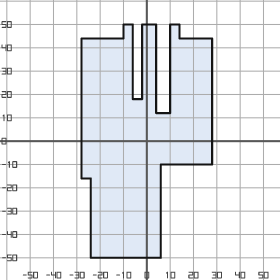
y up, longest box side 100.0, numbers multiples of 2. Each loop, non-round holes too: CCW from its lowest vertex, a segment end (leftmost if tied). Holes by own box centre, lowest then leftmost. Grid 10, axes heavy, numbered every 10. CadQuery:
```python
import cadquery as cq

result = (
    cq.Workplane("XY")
    .moveTo(-24.0, -50.0)
    .lineTo(6.0, -50.0)
    .lineTo(6.0, -10.0)
    .lineTo(28.0, -10.0)
    .lineTo(28.0, 44.0)
    .lineTo(14.0, 44.0)
    .lineTo(14.0, 50.0)
    .lineTo(10.0, 50.0)
    .lineTo(10.0, 12.0)
    .lineTo(4.0, 12.0)
    .lineTo(4.0, 50.0)
    .lineTo(-2.0, 50.0)
    .lineTo(-2.0, 18.0)
    .lineTo(-6.0, 18.0)
    .lineTo(-6.0, 50.0)
    .lineTo(-10.0, 50.0)
    .lineTo(-10.0, 44.0)
    .lineTo(-28.0, 44.0)
    .lineTo(-28.0, -16.0)
    .lineTo(-24.0, -16.0)
    .close()
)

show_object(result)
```